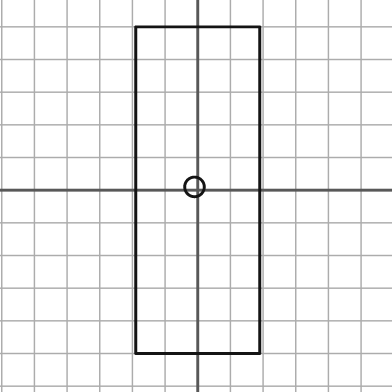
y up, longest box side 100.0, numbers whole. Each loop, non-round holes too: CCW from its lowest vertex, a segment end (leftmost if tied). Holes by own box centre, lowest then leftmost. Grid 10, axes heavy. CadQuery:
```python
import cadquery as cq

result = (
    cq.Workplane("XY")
    .moveTo(-19.0, -50.0)
    .lineTo(19.0, -50.0)
    .lineTo(19.0, 50.0)
    .lineTo(-19.0, 50.0)
    .close()
    .moveTo(-1.0, 1.0)
    .circle(3.0)
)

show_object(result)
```